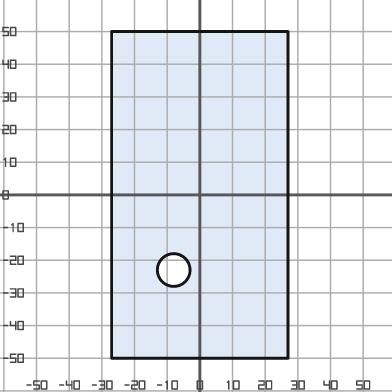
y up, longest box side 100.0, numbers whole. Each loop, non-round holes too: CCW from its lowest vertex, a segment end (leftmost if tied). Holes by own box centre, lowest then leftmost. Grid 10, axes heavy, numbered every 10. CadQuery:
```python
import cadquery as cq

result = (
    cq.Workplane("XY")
    .moveTo(-27.0, -50.0)
    .lineTo(27.0, -50.0)
    .lineTo(27.0, 50.0)
    .lineTo(-27.0, 50.0)
    .close()
    .moveTo(-8.0, -23.0)
    .circle(5.0)
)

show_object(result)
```